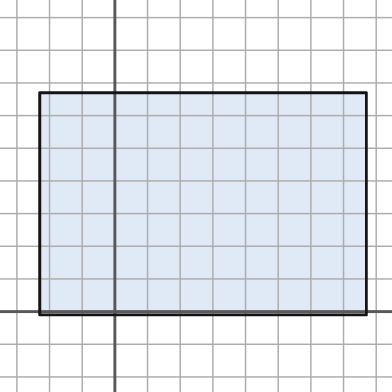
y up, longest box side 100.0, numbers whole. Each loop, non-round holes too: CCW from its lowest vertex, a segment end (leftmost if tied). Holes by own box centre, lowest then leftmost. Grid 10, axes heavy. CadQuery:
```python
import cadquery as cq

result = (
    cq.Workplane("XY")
    .moveTo(-23.0, -1.0)
    .lineTo(77.0, -1.0)
    .lineTo(77.0, 67.0)
    .lineTo(-23.0, 67.0)
    .close()
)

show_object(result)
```